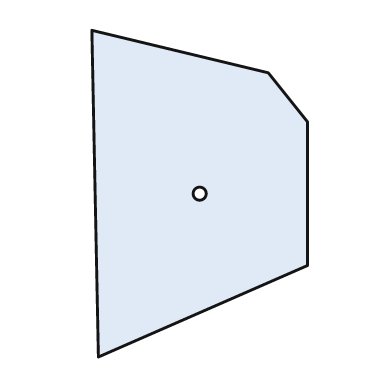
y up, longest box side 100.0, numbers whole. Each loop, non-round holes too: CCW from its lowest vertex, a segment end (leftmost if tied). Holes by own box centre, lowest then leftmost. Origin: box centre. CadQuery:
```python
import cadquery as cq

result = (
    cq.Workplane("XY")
    .moveTo(-31.0, -50.0)
    .lineTo(33.0, -22.0)
    .lineTo(33.0, 22.0)
    .lineTo(21.0, 37.0)
    .lineTo(-33.0, 50.0)
    .close()
    .moveTo(0.0, 0.0)
    .circle(2.0)
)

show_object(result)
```